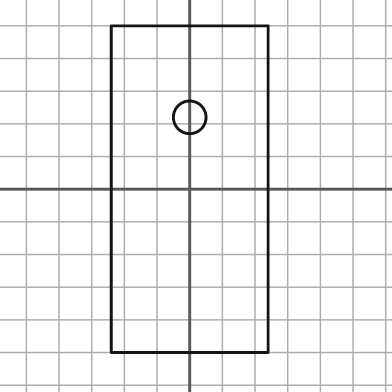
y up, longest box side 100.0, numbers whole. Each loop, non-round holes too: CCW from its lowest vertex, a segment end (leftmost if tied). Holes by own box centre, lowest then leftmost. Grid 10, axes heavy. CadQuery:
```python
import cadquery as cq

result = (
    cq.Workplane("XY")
    .moveTo(-24.0, -50.0)
    .lineTo(24.0, -50.0)
    .lineTo(24.0, 50.0)
    .lineTo(-24.0, 50.0)
    .close()
    .moveTo(0.0, 22.0)
    .circle(5.0)
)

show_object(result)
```